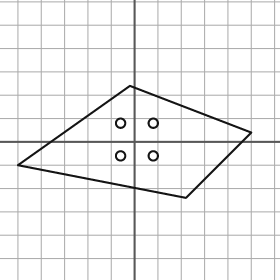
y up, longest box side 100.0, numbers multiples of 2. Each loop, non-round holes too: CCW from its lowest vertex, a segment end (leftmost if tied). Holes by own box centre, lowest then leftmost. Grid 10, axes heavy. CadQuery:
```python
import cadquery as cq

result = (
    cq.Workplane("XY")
    .moveTo(22.0, -24.0)
    .lineTo(50.0, 4.0)
    .lineTo(-2.0, 24.0)
    .lineTo(-50.0, -10.0)
    .close()
    .moveTo(-6.0, -6.0)
    .circle(2.0)
    .moveTo(8.0, -6.0)
    .circle(2.0)
    .moveTo(-6.0, 8.0)
    .circle(2.0)
    .moveTo(8.0, 8.0)
    .circle(2.0)
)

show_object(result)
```